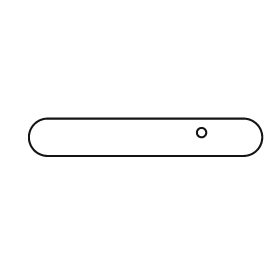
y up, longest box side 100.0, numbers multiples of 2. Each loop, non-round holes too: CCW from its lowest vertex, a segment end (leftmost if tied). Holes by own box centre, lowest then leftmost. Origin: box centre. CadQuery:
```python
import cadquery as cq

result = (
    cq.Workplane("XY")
    .moveTo(-42.0, -8.0)
    .lineTo(42.0, -8.0)
    .threePointArc((50.0, 0.0), (42.0, 8.0))
    .lineTo(-42.0, 8.0)
    .threePointArc((-50.0, 0.0), (-42.0, -8.0))
    .close()
    .moveTo(24.0, 2.0)
    .circle(2.0)
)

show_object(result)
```